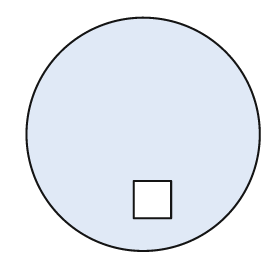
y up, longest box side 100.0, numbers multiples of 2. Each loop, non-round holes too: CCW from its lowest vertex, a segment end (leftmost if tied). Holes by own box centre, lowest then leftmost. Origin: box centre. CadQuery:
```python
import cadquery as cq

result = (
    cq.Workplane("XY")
    .moveTo(0.0, 0.0)
    .circle(50.0)
    .moveTo(-4.0, -36.0)
    .lineTo(12.0, -36.0)
    .lineTo(12.0, -20.0)
    .lineTo(-4.0, -20.0)
    .close()
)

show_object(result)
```